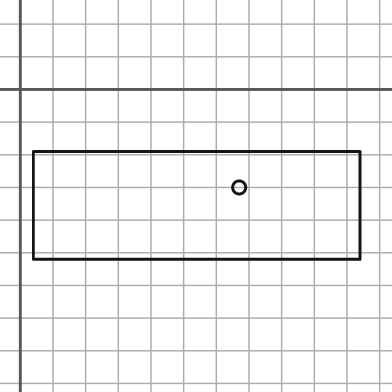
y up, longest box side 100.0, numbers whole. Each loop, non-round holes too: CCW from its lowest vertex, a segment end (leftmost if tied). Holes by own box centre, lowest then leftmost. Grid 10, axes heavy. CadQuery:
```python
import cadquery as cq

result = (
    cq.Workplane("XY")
    .moveTo(4.0, -52.0)
    .lineTo(104.0, -52.0)
    .lineTo(104.0, -19.0)
    .lineTo(4.0, -19.0)
    .close()
    .moveTo(67.0, -30.0)
    .circle(2.0)
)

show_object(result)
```